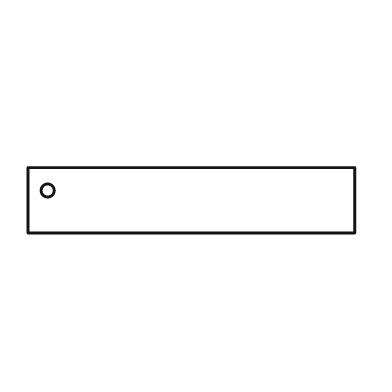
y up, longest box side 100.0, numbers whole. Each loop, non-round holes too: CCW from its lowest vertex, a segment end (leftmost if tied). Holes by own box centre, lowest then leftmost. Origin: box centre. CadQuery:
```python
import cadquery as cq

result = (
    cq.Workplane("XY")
    .moveTo(-50.0, -10.0)
    .lineTo(50.0, -10.0)
    .lineTo(50.0, 10.0)
    .lineTo(-50.0, 10.0)
    .close()
    .moveTo(-44.0, 3.0)
    .circle(2.0)
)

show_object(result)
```